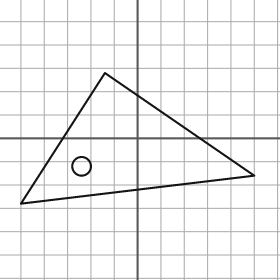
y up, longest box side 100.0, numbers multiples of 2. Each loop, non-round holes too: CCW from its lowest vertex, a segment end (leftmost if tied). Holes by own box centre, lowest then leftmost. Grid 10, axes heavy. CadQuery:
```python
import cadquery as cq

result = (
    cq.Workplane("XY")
    .moveTo(-50.0, -28.0)
    .lineTo(50.0, -16.0)
    .lineTo(-14.0, 28.0)
    .close()
    .moveTo(-24.0, -12.0)
    .circle(4.0)
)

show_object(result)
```